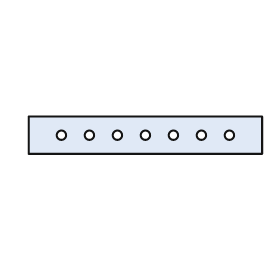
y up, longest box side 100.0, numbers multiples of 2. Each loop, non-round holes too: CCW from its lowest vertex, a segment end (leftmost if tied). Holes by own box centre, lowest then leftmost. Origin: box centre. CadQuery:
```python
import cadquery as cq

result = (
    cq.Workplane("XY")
    .moveTo(-50.0, -8.0)
    .lineTo(50.0, -8.0)
    .lineTo(50.0, 8.0)
    .lineTo(-50.0, 8.0)
    .close()
    .moveTo(-36.0, 0.0)
    .circle(2.0)
    .moveTo(-24.0, 0.0)
    .circle(2.0)
    .moveTo(-12.0, 0.0)
    .circle(2.0)
    .moveTo(0.0, 0.0)
    .circle(2.0)
    .moveTo(12.0, 0.0)
    .circle(2.0)
    .moveTo(24.0, 0.0)
    .circle(2.0)
    .moveTo(36.0, 0.0)
    .circle(2.0)
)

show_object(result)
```